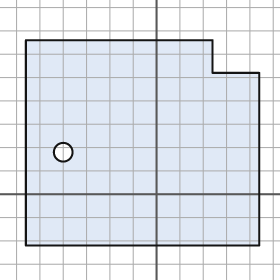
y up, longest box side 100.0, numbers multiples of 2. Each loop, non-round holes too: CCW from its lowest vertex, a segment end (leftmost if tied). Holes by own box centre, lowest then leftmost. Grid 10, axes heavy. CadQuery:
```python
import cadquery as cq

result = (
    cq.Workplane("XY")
    .moveTo(-56.0, -22.0)
    .lineTo(44.0, -22.0)
    .lineTo(44.0, 52.0)
    .lineTo(24.0, 52.0)
    .lineTo(24.0, 66.0)
    .lineTo(-56.0, 66.0)
    .close()
    .moveTo(-40.0, 18.0)
    .circle(4.0)
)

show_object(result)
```